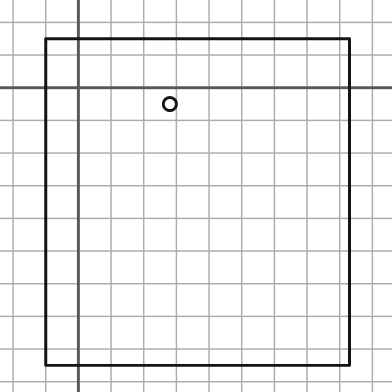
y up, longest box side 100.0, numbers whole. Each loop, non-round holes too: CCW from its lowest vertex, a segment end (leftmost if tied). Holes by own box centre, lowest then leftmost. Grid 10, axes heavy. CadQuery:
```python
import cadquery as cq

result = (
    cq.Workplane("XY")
    .moveTo(-10.0, -85.0)
    .lineTo(83.0, -85.0)
    .lineTo(83.0, 15.0)
    .lineTo(-10.0, 15.0)
    .close()
    .moveTo(28.0, -5.0)
    .circle(2.0)
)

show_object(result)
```